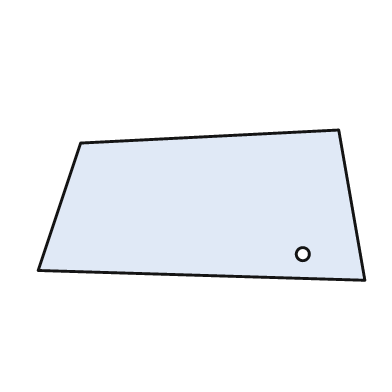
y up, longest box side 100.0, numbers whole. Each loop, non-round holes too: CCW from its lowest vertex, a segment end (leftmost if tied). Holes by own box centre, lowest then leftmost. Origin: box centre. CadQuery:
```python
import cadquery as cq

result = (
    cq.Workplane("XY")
    .moveTo(50.0, -23.0)
    .lineTo(42.0, 23.0)
    .lineTo(-37.0, 19.0)
    .lineTo(-50.0, -20.0)
    .close()
    .moveTo(31.0, -15.0)
    .circle(2.0)
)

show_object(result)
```